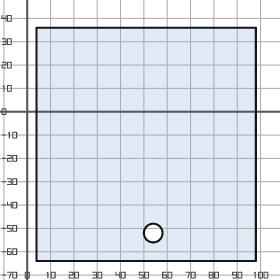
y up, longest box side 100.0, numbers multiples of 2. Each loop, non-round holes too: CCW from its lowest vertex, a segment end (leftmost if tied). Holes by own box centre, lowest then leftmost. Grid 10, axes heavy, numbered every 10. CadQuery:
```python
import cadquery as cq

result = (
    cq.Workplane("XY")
    .moveTo(4.0, -64.0)
    .lineTo(98.0, -64.0)
    .lineTo(98.0, 36.0)
    .lineTo(4.0, 36.0)
    .close()
    .moveTo(54.0, -52.0)
    .circle(4.0)
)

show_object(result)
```